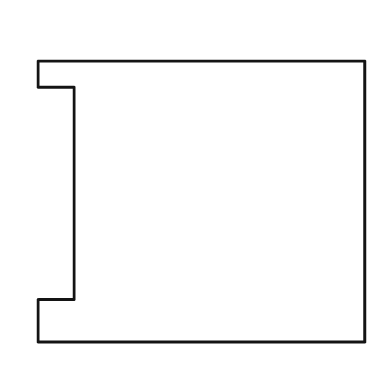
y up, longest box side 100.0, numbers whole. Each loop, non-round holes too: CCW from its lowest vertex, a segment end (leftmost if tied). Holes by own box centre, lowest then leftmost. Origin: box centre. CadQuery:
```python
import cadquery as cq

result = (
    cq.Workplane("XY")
    .moveTo(-50.0, -43.0)
    .lineTo(50.0, -43.0)
    .lineTo(50.0, 43.0)
    .lineTo(-50.0, 43.0)
    .lineTo(-50.0, 35.0)
    .lineTo(-39.0, 35.0)
    .lineTo(-39.0, -30.0)
    .lineTo(-50.0, -30.0)
    .close()
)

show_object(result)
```